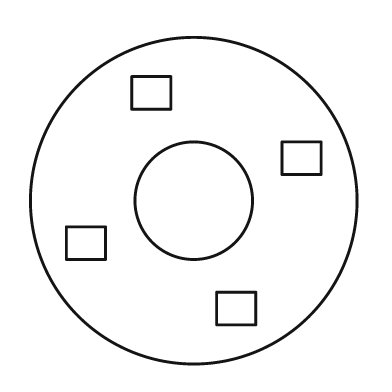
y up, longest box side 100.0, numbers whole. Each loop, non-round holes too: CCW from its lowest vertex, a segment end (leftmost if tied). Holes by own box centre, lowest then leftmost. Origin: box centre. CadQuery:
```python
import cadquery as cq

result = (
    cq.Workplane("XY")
    .moveTo(0.0, 0.0)
    .circle(50.0)
    .moveTo(7.0, -38.0)
    .lineTo(19.0, -38.0)
    .lineTo(19.0, -28.0)
    .lineTo(7.0, -28.0)
    .close()
    .moveTo(-39.0, -18.0)
    .lineTo(-27.0, -18.0)
    .lineTo(-27.0, -8.0)
    .lineTo(-39.0, -8.0)
    .close()
    .moveTo(0.0, 0.0)
    .circle(18.0)
    .moveTo(27.0, 8.0)
    .lineTo(39.0, 8.0)
    .lineTo(39.0, 18.0)
    .lineTo(27.0, 18.0)
    .close()
    .moveTo(-19.0, 28.0)
    .lineTo(-7.0, 28.0)
    .lineTo(-7.0, 38.0)
    .lineTo(-19.0, 38.0)
    .close()
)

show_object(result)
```